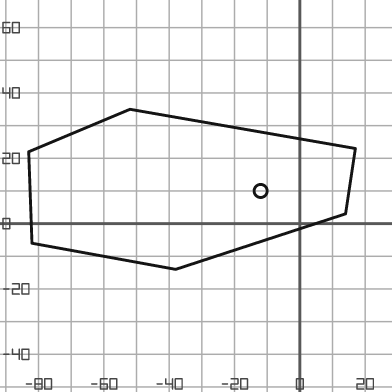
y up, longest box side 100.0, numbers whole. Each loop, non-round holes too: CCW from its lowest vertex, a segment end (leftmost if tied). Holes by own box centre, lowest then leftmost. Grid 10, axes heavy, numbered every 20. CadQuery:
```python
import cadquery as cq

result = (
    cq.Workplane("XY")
    .moveTo(-38.0, -14.0)
    .lineTo(14.0, 3.0)
    .lineTo(17.0, 23.0)
    .lineTo(-52.0, 35.0)
    .lineTo(-83.0, 22.0)
    .lineTo(-82.0, -6.0)
    .close()
    .moveTo(-12.0, 10.0)
    .circle(2.0)
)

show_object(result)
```